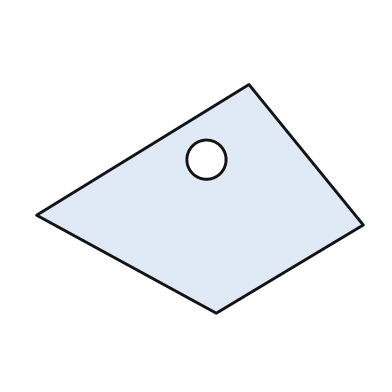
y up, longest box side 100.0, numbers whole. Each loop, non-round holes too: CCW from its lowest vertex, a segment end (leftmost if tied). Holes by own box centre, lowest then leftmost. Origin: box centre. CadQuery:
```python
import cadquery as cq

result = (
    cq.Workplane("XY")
    .moveTo(5.0, -35.0)
    .lineTo(50.0, -8.0)
    .lineTo(15.0, 35.0)
    .lineTo(-50.0, -5.0)
    .close()
    .moveTo(2.0, 12.0)
    .circle(6.0)
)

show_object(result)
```